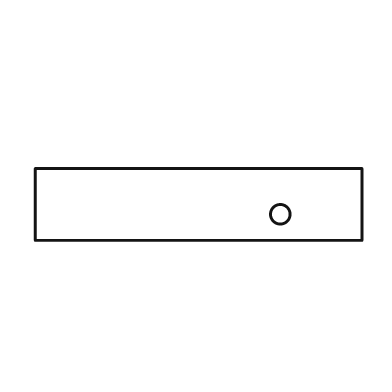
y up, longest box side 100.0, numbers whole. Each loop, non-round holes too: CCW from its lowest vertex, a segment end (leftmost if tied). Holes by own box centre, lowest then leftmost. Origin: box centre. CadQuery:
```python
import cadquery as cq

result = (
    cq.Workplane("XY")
    .moveTo(-50.0, -11.0)
    .lineTo(50.0, -11.0)
    .lineTo(50.0, 11.0)
    .lineTo(-50.0, 11.0)
    .close()
    .moveTo(25.0, -3.0)
    .circle(3.0)
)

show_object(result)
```